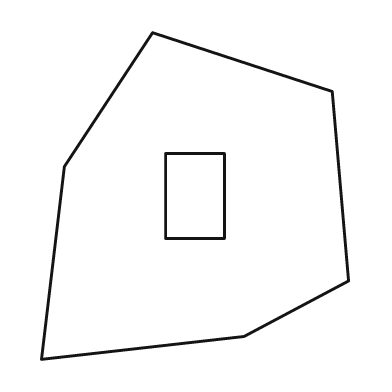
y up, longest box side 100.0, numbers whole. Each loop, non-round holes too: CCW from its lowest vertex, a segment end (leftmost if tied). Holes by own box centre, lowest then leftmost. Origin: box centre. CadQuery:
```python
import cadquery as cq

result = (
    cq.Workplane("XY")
    .moveTo(-47.0, -50.0)
    .lineTo(15.0, -43.0)
    .lineTo(47.0, -26.0)
    .lineTo(42.0, 32.0)
    .lineTo(-13.0, 50.0)
    .lineTo(-40.0, 9.0)
    .close()
    .moveTo(-9.0, -13.0)
    .lineTo(9.0, -13.0)
    .lineTo(9.0, 13.0)
    .lineTo(-9.0, 13.0)
    .close()
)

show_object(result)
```